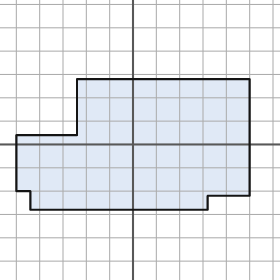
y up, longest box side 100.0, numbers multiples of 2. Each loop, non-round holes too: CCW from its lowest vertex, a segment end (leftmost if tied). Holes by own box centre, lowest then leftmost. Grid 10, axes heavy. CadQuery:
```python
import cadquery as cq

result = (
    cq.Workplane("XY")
    .moveTo(-44.0, -28.0)
    .lineTo(32.0, -28.0)
    .lineTo(32.0, -22.0)
    .lineTo(50.0, -22.0)
    .lineTo(50.0, 28.0)
    .lineTo(-24.0, 28.0)
    .lineTo(-24.0, 4.0)
    .lineTo(-50.0, 4.0)
    .lineTo(-50.0, -20.0)
    .lineTo(-44.0, -20.0)
    .close()
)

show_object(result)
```